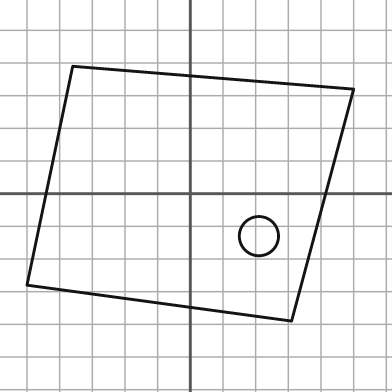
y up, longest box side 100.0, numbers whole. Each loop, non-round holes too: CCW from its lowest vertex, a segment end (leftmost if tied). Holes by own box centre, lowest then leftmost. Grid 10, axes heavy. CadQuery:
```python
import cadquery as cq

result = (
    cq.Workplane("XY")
    .moveTo(31.0, -39.0)
    .lineTo(50.0, 32.0)
    .lineTo(-36.0, 39.0)
    .lineTo(-50.0, -28.0)
    .close()
    .moveTo(21.0, -13.0)
    .circle(6.0)
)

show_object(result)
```